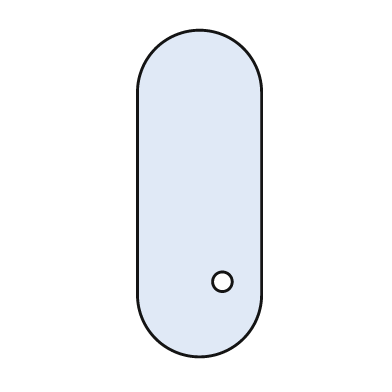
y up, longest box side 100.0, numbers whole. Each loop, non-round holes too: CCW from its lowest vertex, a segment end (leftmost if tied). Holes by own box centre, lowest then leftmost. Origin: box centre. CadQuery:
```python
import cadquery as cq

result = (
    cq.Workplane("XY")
    .moveTo(-19.0, -31.0)
    .threePointArc((0.0, -50.0), (19.0, -31.0))
    .lineTo(19.0, 31.0)
    .threePointArc((0.0, 50.0), (-19.0, 31.0))
    .close()
    .moveTo(7.0, -27.0)
    .circle(3.0)
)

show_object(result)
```